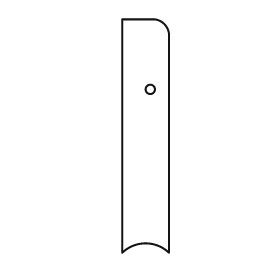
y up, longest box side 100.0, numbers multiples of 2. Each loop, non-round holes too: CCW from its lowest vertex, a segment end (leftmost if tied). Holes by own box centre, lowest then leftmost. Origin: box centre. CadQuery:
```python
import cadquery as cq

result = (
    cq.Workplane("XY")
    .moveTo(-10.0, -50.0)
    .threePointArc((0.0, -46.0), (10.0, -50.0))
    .lineTo(10.0, 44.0)
    .threePointArc((8.0, 48.0), (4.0, 50.0))
    .lineTo(-10.0, 50.0)
    .close()
    .moveTo(2.0, 20.0)
    .circle(2.0)
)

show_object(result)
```